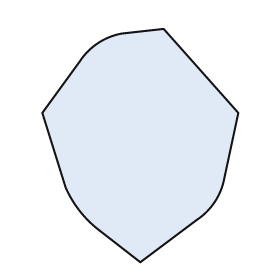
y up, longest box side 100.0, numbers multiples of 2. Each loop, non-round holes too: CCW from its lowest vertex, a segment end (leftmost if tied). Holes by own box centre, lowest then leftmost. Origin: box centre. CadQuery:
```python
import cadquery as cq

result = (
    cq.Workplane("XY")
    .moveTo(0.0, -50.0)
    .lineTo(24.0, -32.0)
    .threePointArc((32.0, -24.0), (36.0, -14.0))
    .lineTo(42.0, 14.0)
    .lineTo(10.0, 50.0)
    .lineTo(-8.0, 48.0)
    .threePointArc((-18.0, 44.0), (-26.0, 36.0))
    .lineTo(-42.0, 14.0)
    .lineTo(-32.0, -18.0)
    .threePointArc((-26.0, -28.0), (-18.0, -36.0))
    .close()
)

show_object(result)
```